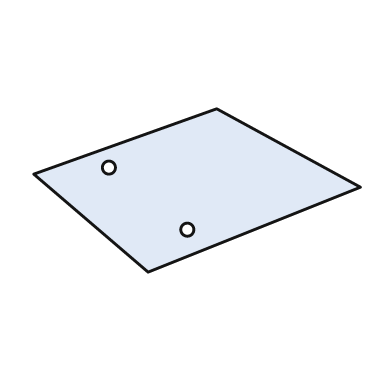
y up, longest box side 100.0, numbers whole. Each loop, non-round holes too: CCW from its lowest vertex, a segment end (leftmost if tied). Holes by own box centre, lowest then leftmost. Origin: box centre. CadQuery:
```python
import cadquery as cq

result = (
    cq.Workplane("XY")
    .moveTo(-15.0, -25.0)
    .lineTo(50.0, 1.0)
    .lineTo(6.0, 25.0)
    .lineTo(-50.0, 5.0)
    .close()
    .moveTo(-3.0, -12.0)
    .circle(2.0)
    .moveTo(-27.0, 7.0)
    .circle(2.0)
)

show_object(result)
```